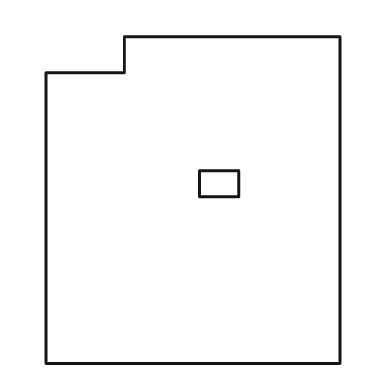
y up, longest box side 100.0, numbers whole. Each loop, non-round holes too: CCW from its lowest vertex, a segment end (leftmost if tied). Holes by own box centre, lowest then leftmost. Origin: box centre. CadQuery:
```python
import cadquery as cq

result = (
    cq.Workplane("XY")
    .moveTo(-45.0, -50.0)
    .lineTo(45.0, -50.0)
    .lineTo(45.0, 50.0)
    .lineTo(-21.0, 50.0)
    .lineTo(-21.0, 39.0)
    .lineTo(-45.0, 39.0)
    .close()
    .moveTo(2.0, 1.0)
    .lineTo(14.0, 1.0)
    .lineTo(14.0, 9.0)
    .lineTo(2.0, 9.0)
    .close()
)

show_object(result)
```